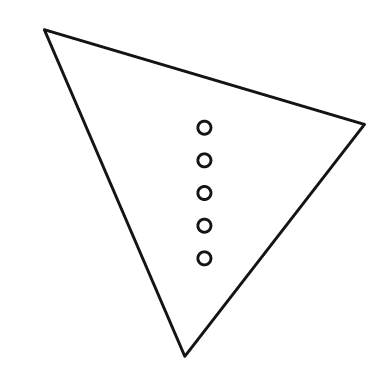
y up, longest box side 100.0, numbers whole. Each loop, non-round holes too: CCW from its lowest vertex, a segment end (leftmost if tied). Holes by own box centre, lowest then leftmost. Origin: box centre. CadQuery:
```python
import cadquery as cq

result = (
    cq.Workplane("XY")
    .moveTo(-6.0, -50.0)
    .lineTo(49.0, 21.0)
    .lineTo(-49.0, 50.0)
    .close()
    .moveTo(0.0, -20.0)
    .circle(2.0)
    .moveTo(0.0, -10.0)
    .circle(2.0)
    .moveTo(0.0, 0.0)
    .circle(2.0)
    .moveTo(0.0, 10.0)
    .circle(2.0)
    .moveTo(0.0, 20.0)
    .circle(2.0)
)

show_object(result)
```